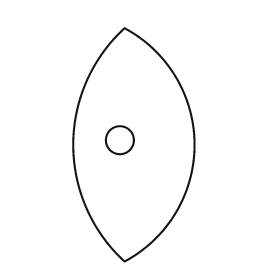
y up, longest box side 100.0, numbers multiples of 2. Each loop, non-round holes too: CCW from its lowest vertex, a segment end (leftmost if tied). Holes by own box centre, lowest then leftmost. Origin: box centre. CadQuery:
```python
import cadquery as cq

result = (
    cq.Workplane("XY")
    .moveTo(-4.0, -50.0)
    .threePointArc((26.0, 0.0), (-4.0, 50.0))
    .threePointArc((-26.0, 0.0), (-4.0, -50.0))
    .close()
    .moveTo(-6.0, 2.0)
    .circle(6.0)
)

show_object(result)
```